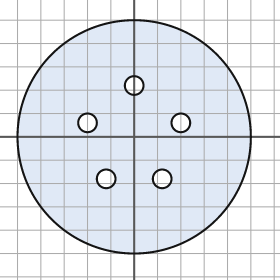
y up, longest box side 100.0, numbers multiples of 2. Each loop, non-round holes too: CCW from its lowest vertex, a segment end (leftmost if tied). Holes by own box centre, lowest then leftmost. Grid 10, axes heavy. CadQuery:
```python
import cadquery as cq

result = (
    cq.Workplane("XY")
    .moveTo(0.0, 0.0)
    .circle(50.0)
    .moveTo(-12.0, -18.0)
    .circle(4.0)
    .moveTo(12.0, -18.0)
    .circle(4.0)
    .moveTo(-20.0, 6.0)
    .circle(4.0)
    .moveTo(20.0, 6.0)
    .circle(4.0)
    .moveTo(0.0, 22.0)
    .circle(4.0)
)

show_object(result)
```